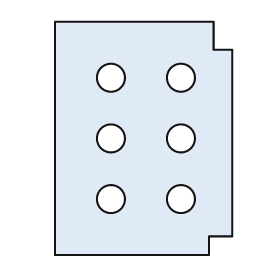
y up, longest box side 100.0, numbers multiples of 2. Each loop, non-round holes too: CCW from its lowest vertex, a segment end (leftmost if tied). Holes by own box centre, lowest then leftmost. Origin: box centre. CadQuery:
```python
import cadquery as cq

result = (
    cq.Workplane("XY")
    .moveTo(-38.0, -50.0)
    .lineTo(28.0, -50.0)
    .lineTo(28.0, -42.0)
    .lineTo(38.0, -42.0)
    .lineTo(38.0, 38.0)
    .lineTo(30.0, 38.0)
    .lineTo(30.0, 50.0)
    .lineTo(-38.0, 50.0)
    .close()
    .moveTo(-14.0, -26.0)
    .circle(6.0)
    .moveTo(16.0, -26.0)
    .circle(6.0)
    .moveTo(-14.0, 0.0)
    .circle(6.0)
    .moveTo(16.0, 0.0)
    .circle(6.0)
    .moveTo(-14.0, 26.0)
    .circle(6.0)
    .moveTo(16.0, 26.0)
    .circle(6.0)
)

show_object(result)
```